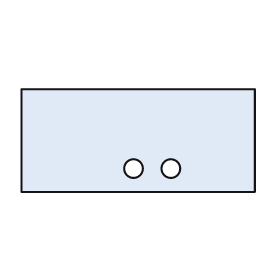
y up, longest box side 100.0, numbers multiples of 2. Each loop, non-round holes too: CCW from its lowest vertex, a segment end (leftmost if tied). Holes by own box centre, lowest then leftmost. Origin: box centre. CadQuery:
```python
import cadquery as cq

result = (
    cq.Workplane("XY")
    .moveTo(-50.0, -22.0)
    .lineTo(50.0, -22.0)
    .lineTo(50.0, 22.0)
    .lineTo(-50.0, 22.0)
    .close()
    .moveTo(-2.0, -12.0)
    .circle(4.0)
    .moveTo(14.0, -12.0)
    .circle(4.0)
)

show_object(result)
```